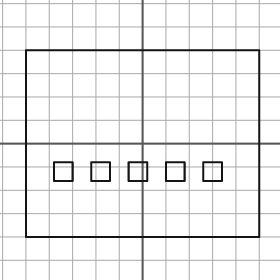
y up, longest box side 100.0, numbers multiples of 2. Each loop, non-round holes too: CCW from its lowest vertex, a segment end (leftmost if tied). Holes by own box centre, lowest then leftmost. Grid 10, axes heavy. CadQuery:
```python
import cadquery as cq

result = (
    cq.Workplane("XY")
    .moveTo(-50.0, -40.0)
    .lineTo(50.0, -40.0)
    .lineTo(50.0, 40.0)
    .lineTo(-50.0, 40.0)
    .close()
    .moveTo(-38.0, -16.0)
    .lineTo(-30.0, -16.0)
    .lineTo(-30.0, -8.0)
    .lineTo(-38.0, -8.0)
    .close()
    .moveTo(-22.0, -16.0)
    .lineTo(-14.0, -16.0)
    .lineTo(-14.0, -8.0)
    .lineTo(-22.0, -8.0)
    .close()
    .moveTo(-6.0, -16.0)
    .lineTo(2.0, -16.0)
    .lineTo(2.0, -8.0)
    .lineTo(-6.0, -8.0)
    .close()
    .moveTo(10.0, -16.0)
    .lineTo(18.0, -16.0)
    .lineTo(18.0, -8.0)
    .lineTo(10.0, -8.0)
    .close()
    .moveTo(26.0, -16.0)
    .lineTo(34.0, -16.0)
    .lineTo(34.0, -8.0)
    .lineTo(26.0, -8.0)
    .close()
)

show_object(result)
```